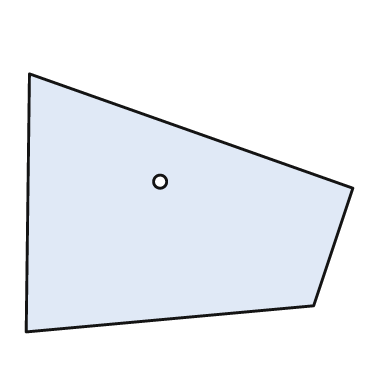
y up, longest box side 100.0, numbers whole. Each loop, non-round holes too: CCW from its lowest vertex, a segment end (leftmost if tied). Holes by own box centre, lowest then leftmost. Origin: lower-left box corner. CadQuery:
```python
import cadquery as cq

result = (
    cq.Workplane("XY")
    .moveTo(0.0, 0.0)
    .lineTo(88.0, 8.0)
    .lineTo(100.0, 44.0)
    .lineTo(1.0, 79.0)
    .close()
    .moveTo(41.0, 46.0)
    .circle(2.0)
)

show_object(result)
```